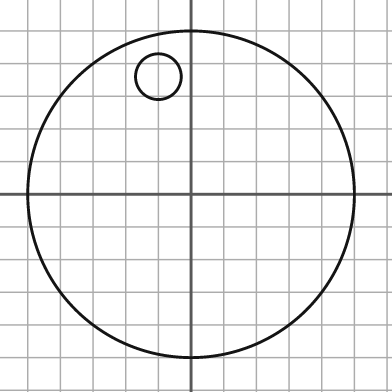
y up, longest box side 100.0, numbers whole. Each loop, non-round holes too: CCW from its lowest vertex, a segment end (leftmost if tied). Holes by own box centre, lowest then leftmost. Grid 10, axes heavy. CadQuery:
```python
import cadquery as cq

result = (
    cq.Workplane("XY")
    .moveTo(0.0, 0.0)
    .circle(50.0)
    .moveTo(-10.0, 36.0)
    .circle(7.0)
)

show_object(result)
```